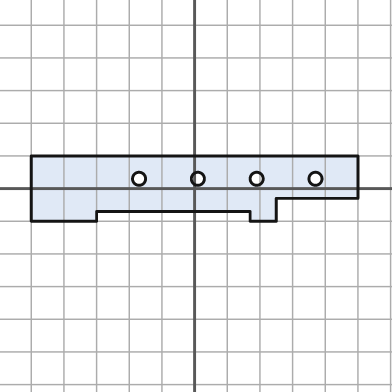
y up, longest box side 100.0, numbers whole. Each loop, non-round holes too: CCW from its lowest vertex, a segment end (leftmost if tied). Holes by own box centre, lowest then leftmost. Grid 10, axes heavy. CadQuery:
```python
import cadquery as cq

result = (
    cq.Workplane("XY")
    .moveTo(-50.0, -10.0)
    .lineTo(-30.0, -10.0)
    .lineTo(-30.0, -7.0)
    .lineTo(17.0, -7.0)
    .lineTo(17.0, -10.0)
    .lineTo(25.0, -10.0)
    .lineTo(25.0, -3.0)
    .lineTo(50.0, -3.0)
    .lineTo(50.0, 10.0)
    .lineTo(-50.0, 10.0)
    .close()
    .moveTo(-17.0, 3.0)
    .circle(2.0)
    .moveTo(1.0, 3.0)
    .circle(2.0)
    .moveTo(19.0, 3.0)
    .circle(2.0)
    .moveTo(37.0, 3.0)
    .circle(2.0)
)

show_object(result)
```